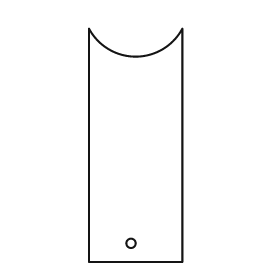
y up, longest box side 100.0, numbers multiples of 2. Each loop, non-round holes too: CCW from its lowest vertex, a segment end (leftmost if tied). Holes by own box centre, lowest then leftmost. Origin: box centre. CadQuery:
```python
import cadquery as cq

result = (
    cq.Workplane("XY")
    .moveTo(-20.0, -50.0)
    .lineTo(20.0, -50.0)
    .lineTo(20.0, 50.0)
    .threePointArc((0.0, 38.0), (-20.0, 50.0))
    .close()
    .moveTo(-2.0, -42.0)
    .circle(2.0)
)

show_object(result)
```